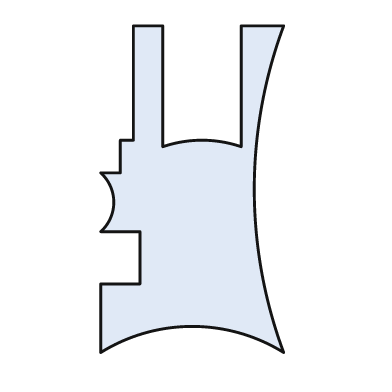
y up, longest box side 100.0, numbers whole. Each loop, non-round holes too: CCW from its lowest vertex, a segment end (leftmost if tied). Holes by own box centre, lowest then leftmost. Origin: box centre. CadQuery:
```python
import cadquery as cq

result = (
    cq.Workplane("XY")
    .moveTo(-28.0, -50.0)
    .threePointArc((0.0, -42.0), (28.0, -50.0))
    .threePointArc((19.0, 0.0), (28.0, 50.0))
    .lineTo(15.0, 50.0)
    .lineTo(15.0, 13.0)
    .threePointArc((3.0, 15.0), (-9.0, 13.0))
    .lineTo(-9.0, 50.0)
    .lineTo(-18.0, 50.0)
    .lineTo(-18.0, 15.0)
    .lineTo(-22.0, 15.0)
    .lineTo(-22.0, 5.0)
    .lineTo(-28.0, 5.0)
    .threePointArc((-24.0, -4.0), (-28.0, -13.0))
    .lineTo(-16.0, -13.0)
    .lineTo(-16.0, -29.0)
    .lineTo(-28.0, -29.0)
    .close()
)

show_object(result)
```